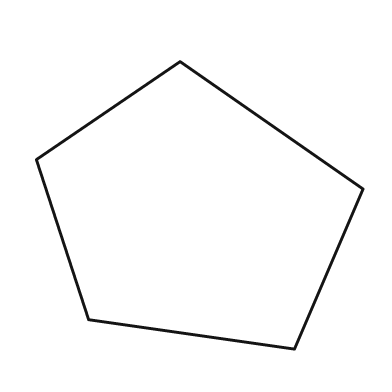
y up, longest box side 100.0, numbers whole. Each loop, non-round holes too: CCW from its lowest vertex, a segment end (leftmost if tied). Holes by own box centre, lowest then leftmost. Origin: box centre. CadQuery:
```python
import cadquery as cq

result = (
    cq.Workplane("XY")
    .moveTo(29.0, -44.0)
    .lineTo(50.0, 5.0)
    .lineTo(-6.0, 44.0)
    .lineTo(-50.0, 14.0)
    .lineTo(-34.0, -35.0)
    .close()
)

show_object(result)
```